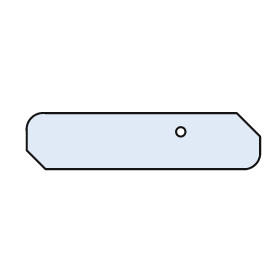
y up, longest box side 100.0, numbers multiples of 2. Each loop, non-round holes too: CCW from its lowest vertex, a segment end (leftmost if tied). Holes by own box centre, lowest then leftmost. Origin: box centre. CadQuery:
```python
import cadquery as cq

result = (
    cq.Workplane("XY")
    .moveTo(-42.0, -12.0)
    .lineTo(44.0, -12.0)
    .threePointArc((48.0, -10.0), (50.0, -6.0))
    .lineTo(50.0, 2.0)
    .lineTo(40.0, 12.0)
    .lineTo(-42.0, 12.0)
    .threePointArc((-48.0, 10.0), (-50.0, 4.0))
    .lineTo(-50.0, -4.0)
    .close()
    .moveTo(16.0, 4.0)
    .circle(2.0)
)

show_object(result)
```